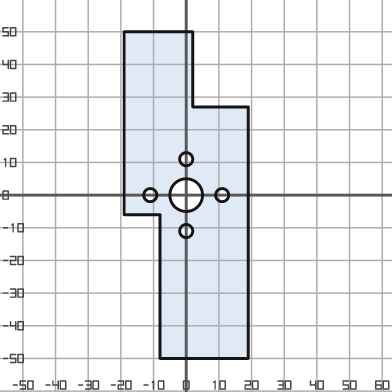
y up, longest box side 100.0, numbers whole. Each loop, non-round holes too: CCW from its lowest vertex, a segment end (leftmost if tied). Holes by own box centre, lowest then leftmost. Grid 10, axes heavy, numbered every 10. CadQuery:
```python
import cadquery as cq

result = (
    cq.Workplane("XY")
    .moveTo(-8.0, -50.0)
    .lineTo(19.0, -50.0)
    .lineTo(19.0, 27.0)
    .lineTo(2.0, 27.0)
    .lineTo(2.0, 50.0)
    .lineTo(-19.0, 50.0)
    .lineTo(-19.0, -6.0)
    .lineTo(-8.0, -6.0)
    .close()
    .moveTo(0.0, -11.0)
    .circle(2.0)
    .moveTo(-11.0, 0.0)
    .circle(2.0)
    .moveTo(0.0, 0.0)
    .circle(5.0)
    .moveTo(11.0, 0.0)
    .circle(2.0)
    .moveTo(0.0, 11.0)
    .circle(2.0)
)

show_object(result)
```